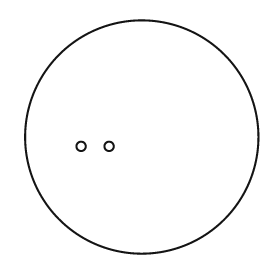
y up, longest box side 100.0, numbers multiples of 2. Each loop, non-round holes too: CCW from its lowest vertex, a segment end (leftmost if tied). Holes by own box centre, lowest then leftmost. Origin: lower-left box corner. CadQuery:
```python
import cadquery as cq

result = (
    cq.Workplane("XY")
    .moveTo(50.0, 50.0)
    .circle(50.0)
    .moveTo(24.0, 46.0)
    .circle(2.0)
    .moveTo(36.0, 46.0)
    .circle(2.0)
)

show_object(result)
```